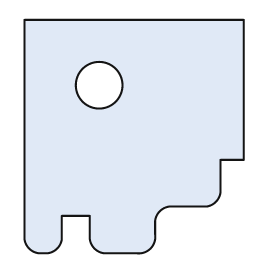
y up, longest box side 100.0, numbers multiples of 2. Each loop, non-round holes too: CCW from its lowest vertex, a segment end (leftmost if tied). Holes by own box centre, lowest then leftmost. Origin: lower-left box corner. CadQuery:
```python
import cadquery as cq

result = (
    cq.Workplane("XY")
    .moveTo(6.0, 0.0)
    .lineTo(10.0, 0.0)
    .threePointArc((14.0, 2.0), (16.0, 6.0))
    .lineTo(16.0, 16.0)
    .lineTo(28.0, 16.0)
    .lineTo(28.0, 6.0)
    .threePointArc((30.0, 2.0), (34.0, 0.0))
    .lineTo(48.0, 0.0)
    .threePointArc((54.0, 2.0), (56.0, 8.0))
    .lineTo(56.0, 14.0)
    .threePointArc((58.0, 18.0), (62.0, 20.0))
    .lineTo(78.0, 20.0)
    .threePointArc((82.0, 22.0), (84.0, 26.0))
    .lineTo(84.0, 40.0)
    .lineTo(94.0, 40.0)
    .lineTo(94.0, 100.0)
    .lineTo(0.0, 100.0)
    .lineTo(0.0, 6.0)
    .threePointArc((2.0, 2.0), (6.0, 0.0))
    .close()
    .moveTo(32.0, 72.0)
    .circle(10.0)
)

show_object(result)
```